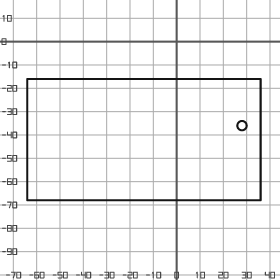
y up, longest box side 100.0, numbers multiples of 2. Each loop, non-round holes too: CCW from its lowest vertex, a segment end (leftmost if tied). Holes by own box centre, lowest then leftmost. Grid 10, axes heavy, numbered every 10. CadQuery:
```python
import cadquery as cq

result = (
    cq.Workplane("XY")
    .moveTo(-64.0, -68.0)
    .lineTo(36.0, -68.0)
    .lineTo(36.0, -16.0)
    .lineTo(-64.0, -16.0)
    .close()
    .moveTo(28.0, -36.0)
    .circle(2.0)
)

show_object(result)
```